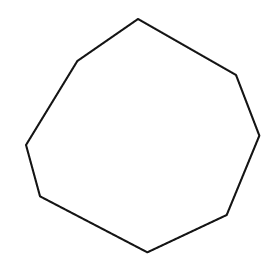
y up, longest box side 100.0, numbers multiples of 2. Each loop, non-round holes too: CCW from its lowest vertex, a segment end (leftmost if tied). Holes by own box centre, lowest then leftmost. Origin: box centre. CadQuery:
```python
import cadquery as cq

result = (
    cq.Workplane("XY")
    .moveTo(2.0, -50.0)
    .lineTo(36.0, -34.0)
    .lineTo(50.0, 0.0)
    .lineTo(40.0, 26.0)
    .lineTo(-2.0, 50.0)
    .lineTo(-28.0, 32.0)
    .lineTo(-50.0, -4.0)
    .lineTo(-44.0, -26.0)
    .close()
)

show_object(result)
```